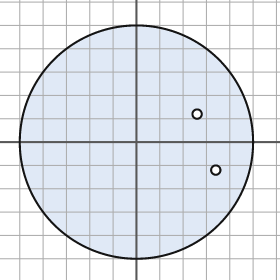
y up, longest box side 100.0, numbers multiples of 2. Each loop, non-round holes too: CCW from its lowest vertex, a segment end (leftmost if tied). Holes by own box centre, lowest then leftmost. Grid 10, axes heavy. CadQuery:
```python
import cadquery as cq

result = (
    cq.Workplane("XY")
    .moveTo(0.0, 0.0)
    .circle(50.0)
    .moveTo(34.0, -12.0)
    .circle(2.0)
    .moveTo(26.0, 12.0)
    .circle(2.0)
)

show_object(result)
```